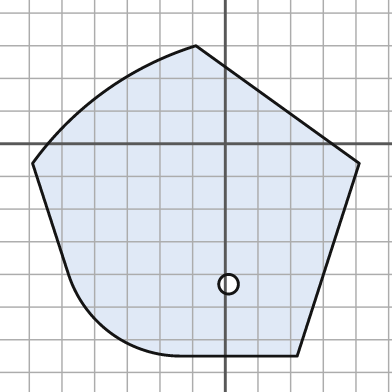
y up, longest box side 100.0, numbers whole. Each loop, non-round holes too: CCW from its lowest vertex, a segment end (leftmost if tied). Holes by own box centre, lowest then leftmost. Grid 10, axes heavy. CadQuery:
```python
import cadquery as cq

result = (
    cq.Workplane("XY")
    .moveTo(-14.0, -65.0)
    .lineTo(22.0, -65.0)
    .lineTo(41.0, -6.0)
    .lineTo(-9.0, 30.0)
    .threePointArc((-37.0, 16.0), (-59.0, -6.0))
    .lineTo(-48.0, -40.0)
    .threePointArc((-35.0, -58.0), (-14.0, -65.0))
    .close()
    .moveTo(1.0, -43.0)
    .circle(3.0)
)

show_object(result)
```